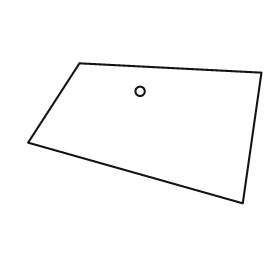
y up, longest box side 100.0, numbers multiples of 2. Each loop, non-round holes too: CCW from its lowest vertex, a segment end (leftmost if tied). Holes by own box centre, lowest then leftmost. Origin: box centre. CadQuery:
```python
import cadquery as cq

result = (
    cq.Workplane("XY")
    .moveTo(42.0, -30.0)
    .lineTo(50.0, 26.0)
    .lineTo(-28.0, 30.0)
    .lineTo(-50.0, -4.0)
    .close()
    .moveTo(-2.0, 18.0)
    .circle(2.0)
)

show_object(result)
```